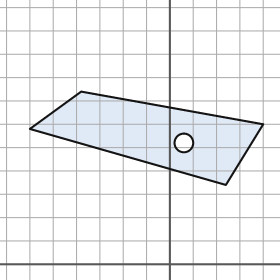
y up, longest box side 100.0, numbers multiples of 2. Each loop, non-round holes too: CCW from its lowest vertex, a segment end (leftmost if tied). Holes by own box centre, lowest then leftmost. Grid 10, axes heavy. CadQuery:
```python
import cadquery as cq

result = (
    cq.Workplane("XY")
    .moveTo(24.0, 34.0)
    .lineTo(40.0, 60.0)
    .lineTo(-38.0, 74.0)
    .lineTo(-60.0, 58.0)
    .close()
    .moveTo(6.0, 52.0)
    .circle(4.0)
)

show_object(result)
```